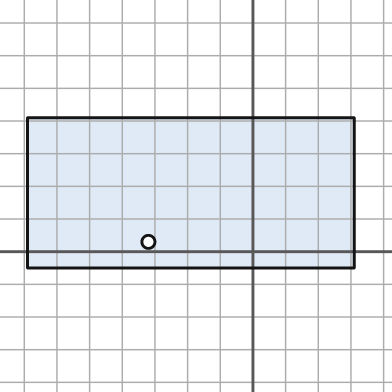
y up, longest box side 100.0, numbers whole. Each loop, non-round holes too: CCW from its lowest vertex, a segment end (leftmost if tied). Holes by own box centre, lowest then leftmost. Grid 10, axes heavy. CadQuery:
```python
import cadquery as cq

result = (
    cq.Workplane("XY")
    .moveTo(-69.0, -5.0)
    .lineTo(31.0, -5.0)
    .lineTo(31.0, 41.0)
    .lineTo(-69.0, 41.0)
    .close()
    .moveTo(-32.0, 3.0)
    .circle(2.0)
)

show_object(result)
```